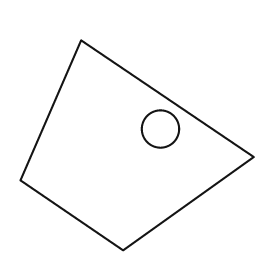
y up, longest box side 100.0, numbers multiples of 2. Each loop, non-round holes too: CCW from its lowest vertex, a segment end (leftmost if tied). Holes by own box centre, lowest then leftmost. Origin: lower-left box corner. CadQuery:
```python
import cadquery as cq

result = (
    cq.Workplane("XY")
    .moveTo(44.0, 0.0)
    .lineTo(100.0, 40.0)
    .lineTo(26.0, 90.0)
    .lineTo(0.0, 30.0)
    .close()
    .moveTo(60.0, 52.0)
    .circle(8.0)
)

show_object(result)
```